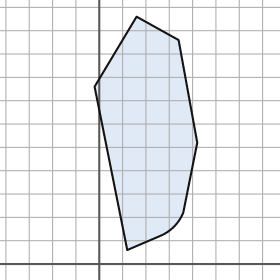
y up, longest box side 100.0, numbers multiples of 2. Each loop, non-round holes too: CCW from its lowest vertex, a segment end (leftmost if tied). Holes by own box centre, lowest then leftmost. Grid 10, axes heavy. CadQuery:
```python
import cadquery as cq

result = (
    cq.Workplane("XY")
    .moveTo(12.0, 6.0)
    .lineTo(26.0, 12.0)
    .threePointArc((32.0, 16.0), (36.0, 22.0))
    .lineTo(42.0, 52.0)
    .lineTo(34.0, 96.0)
    .lineTo(16.0, 106.0)
    .lineTo(-2.0, 76.0)
    .close()
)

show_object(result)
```